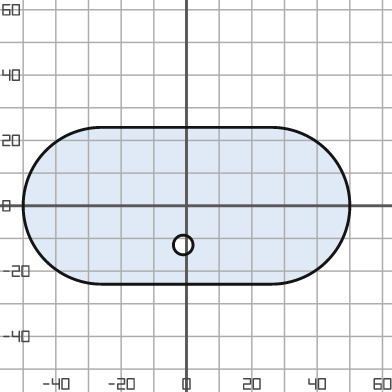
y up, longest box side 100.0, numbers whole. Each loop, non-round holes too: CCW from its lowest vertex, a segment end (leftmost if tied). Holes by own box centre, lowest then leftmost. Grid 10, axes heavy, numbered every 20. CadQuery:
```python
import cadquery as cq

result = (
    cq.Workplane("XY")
    .moveTo(-26.0, -24.0)
    .lineTo(26.0, -24.0)
    .threePointArc((50.0, 0.0), (26.0, 24.0))
    .lineTo(-26.0, 24.0)
    .threePointArc((-50.0, 0.0), (-26.0, -24.0))
    .close()
    .moveTo(-1.0, -12.0)
    .circle(3.0)
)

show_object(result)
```